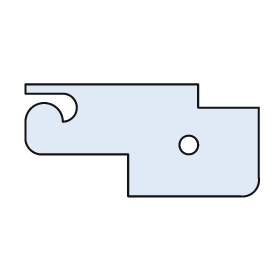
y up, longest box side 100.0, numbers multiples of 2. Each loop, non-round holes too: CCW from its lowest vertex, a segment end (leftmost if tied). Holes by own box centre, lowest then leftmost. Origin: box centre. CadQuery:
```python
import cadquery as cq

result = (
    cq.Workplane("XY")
    .moveTo(-6.0, -24.0)
    .lineTo(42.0, -24.0)
    .threePointArc((48.0, -22.0), (50.0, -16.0))
    .lineTo(50.0, 14.0)
    .lineTo(24.0, 14.0)
    .lineTo(24.0, 24.0)
    .lineTo(-50.0, 24.0)
    .lineTo(-50.0, 20.0)
    .lineTo(-34.0, 20.0)
    .threePointArc((-28.0, 14.0), (-34.0, 8.0))
    .threePointArc((-42.0, 16.0), (-50.0, 8.0))
    .lineTo(-50.0, 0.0)
    .threePointArc((-48.0, -4.0), (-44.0, -6.0))
    .lineTo(-6.0, -6.0)
    .close()
    .moveTo(20.0, -2.0)
    .circle(4.0)
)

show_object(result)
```